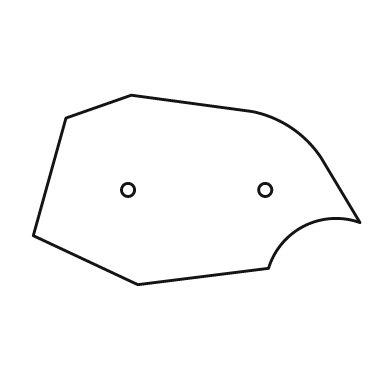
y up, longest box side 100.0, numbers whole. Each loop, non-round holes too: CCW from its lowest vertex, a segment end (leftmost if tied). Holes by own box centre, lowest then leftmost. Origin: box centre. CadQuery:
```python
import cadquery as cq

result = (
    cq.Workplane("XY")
    .moveTo(-18.0, -29.0)
    .lineTo(22.0, -24.0)
    .threePointArc((33.0, -11.0), (50.0, -10.0))
    .lineTo(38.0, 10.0)
    .threePointArc((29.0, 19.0), (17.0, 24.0))
    .lineTo(-20.0, 29.0)
    .lineTo(-40.0, 22.0)
    .lineTo(-50.0, -14.0)
    .close()
    .moveTo(-21.0, 0.0)
    .circle(2.0)
    .moveTo(21.0, 0.0)
    .circle(2.0)
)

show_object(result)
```